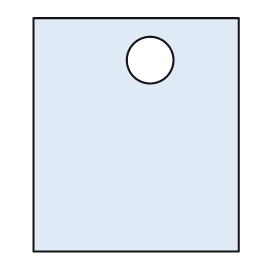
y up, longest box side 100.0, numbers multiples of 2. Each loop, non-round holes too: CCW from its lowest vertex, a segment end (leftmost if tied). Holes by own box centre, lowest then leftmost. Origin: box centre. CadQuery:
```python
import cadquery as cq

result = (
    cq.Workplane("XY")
    .moveTo(-44.0, -50.0)
    .lineTo(44.0, -50.0)
    .lineTo(44.0, 50.0)
    .lineTo(-44.0, 50.0)
    .close()
    .moveTo(6.0, 32.0)
    .circle(10.0)
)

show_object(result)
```